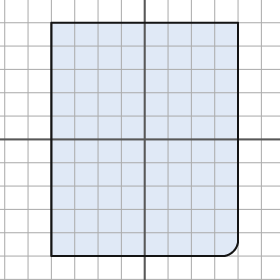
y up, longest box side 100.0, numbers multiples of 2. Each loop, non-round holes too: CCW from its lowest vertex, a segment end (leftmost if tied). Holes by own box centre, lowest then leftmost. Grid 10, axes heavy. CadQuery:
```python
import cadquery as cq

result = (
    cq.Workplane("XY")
    .moveTo(-40.0, -50.0)
    .lineTo(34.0, -50.0)
    .threePointArc((38.0, -48.0), (40.0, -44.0))
    .lineTo(40.0, 50.0)
    .lineTo(-40.0, 50.0)
    .close()
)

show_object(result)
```